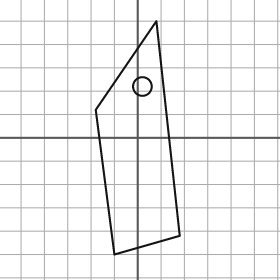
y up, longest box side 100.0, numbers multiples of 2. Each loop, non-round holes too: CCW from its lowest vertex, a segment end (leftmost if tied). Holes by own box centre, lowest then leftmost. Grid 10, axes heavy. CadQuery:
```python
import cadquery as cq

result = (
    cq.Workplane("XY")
    .moveTo(-10.0, -50.0)
    .lineTo(18.0, -42.0)
    .lineTo(8.0, 50.0)
    .lineTo(-18.0, 12.0)
    .close()
    .moveTo(2.0, 22.0)
    .circle(4.0)
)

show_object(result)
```